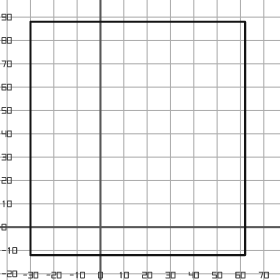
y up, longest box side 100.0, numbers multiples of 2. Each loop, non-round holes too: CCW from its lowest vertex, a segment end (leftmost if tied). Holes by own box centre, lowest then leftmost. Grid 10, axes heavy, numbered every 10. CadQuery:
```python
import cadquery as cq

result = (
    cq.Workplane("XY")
    .moveTo(-30.0, -12.0)
    .lineTo(62.0, -12.0)
    .lineTo(62.0, 88.0)
    .lineTo(-30.0, 88.0)
    .close()
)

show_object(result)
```